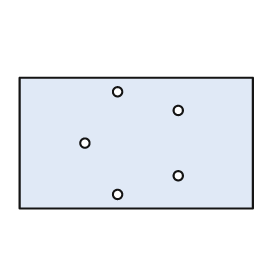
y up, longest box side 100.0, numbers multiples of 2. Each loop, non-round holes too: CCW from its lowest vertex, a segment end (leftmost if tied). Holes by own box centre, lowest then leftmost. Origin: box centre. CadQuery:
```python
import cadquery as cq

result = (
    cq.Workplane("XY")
    .moveTo(-50.0, -28.0)
    .lineTo(50.0, -28.0)
    .lineTo(50.0, 28.0)
    .lineTo(-50.0, 28.0)
    .close()
    .moveTo(-8.0, -22.0)
    .circle(2.0)
    .moveTo(18.0, -14.0)
    .circle(2.0)
    .moveTo(-22.0, 0.0)
    .circle(2.0)
    .moveTo(18.0, 14.0)
    .circle(2.0)
    .moveTo(-8.0, 22.0)
    .circle(2.0)
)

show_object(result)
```